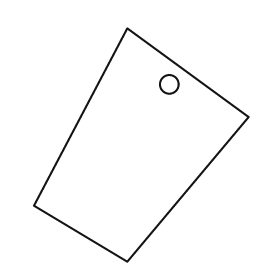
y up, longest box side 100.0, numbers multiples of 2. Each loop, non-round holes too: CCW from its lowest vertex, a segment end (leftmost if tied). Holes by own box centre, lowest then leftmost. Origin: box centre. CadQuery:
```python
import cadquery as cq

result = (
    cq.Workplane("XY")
    .moveTo(-6.0, -50.0)
    .lineTo(46.0, 12.0)
    .lineTo(-6.0, 50.0)
    .lineTo(-46.0, -26.0)
    .close()
    .moveTo(12.0, 26.0)
    .circle(4.0)
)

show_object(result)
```